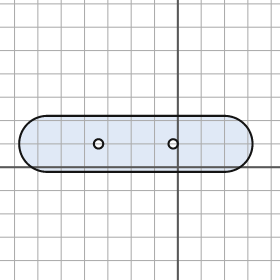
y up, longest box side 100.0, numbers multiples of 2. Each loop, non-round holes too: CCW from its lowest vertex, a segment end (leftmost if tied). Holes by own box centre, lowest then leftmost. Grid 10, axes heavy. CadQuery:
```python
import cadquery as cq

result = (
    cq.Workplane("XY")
    .moveTo(-56.0, -2.0)
    .lineTo(20.0, -2.0)
    .threePointArc((32.0, 10.0), (20.0, 22.0))
    .lineTo(-56.0, 22.0)
    .threePointArc((-68.0, 10.0), (-56.0, -2.0))
    .close()
    .moveTo(-34.0, 10.0)
    .circle(2.0)
    .moveTo(-2.0, 10.0)
    .circle(2.0)
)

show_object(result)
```